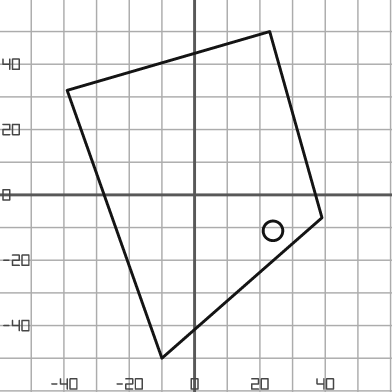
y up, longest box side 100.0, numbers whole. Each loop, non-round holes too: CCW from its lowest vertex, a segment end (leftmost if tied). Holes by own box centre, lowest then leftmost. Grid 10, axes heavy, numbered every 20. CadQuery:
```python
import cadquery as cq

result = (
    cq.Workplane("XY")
    .moveTo(-10.0, -50.0)
    .lineTo(39.0, -7.0)
    .lineTo(23.0, 50.0)
    .lineTo(-39.0, 32.0)
    .close()
    .moveTo(24.0, -11.0)
    .circle(3.0)
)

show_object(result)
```